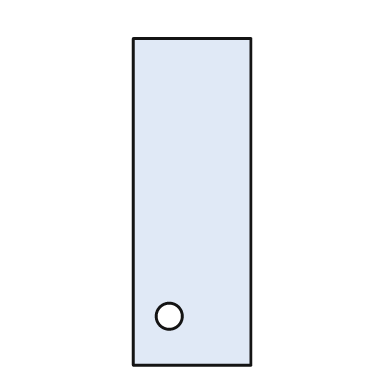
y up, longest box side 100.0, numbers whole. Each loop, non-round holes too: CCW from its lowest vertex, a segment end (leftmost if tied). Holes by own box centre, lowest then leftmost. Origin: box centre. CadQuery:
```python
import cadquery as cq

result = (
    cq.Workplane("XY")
    .moveTo(-18.0, -50.0)
    .lineTo(18.0, -50.0)
    .lineTo(18.0, 50.0)
    .lineTo(-18.0, 50.0)
    .close()
    .moveTo(-7.0, -35.0)
    .circle(4.0)
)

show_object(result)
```